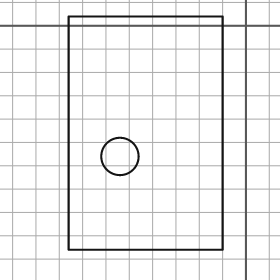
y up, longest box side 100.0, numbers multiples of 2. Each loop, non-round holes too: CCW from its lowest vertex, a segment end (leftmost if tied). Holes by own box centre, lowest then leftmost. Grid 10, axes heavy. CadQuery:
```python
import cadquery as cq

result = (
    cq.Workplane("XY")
    .moveTo(-76.0, -96.0)
    .lineTo(-10.0, -96.0)
    .lineTo(-10.0, 4.0)
    .lineTo(-76.0, 4.0)
    .close()
    .moveTo(-54.0, -56.0)
    .circle(8.0)
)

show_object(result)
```